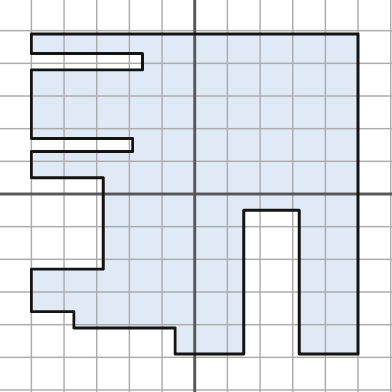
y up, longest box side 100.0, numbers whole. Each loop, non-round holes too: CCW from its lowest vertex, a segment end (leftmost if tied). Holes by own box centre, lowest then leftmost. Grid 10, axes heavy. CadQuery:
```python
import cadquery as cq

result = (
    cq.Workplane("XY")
    .moveTo(-6.0, -49.0)
    .lineTo(15.0, -49.0)
    .lineTo(15.0, -5.0)
    .lineTo(32.0, -5.0)
    .lineTo(32.0, -49.0)
    .lineTo(50.0, -49.0)
    .lineTo(50.0, 49.0)
    .lineTo(-50.0, 49.0)
    .lineTo(-50.0, 43.0)
    .lineTo(-16.0, 43.0)
    .lineTo(-16.0, 38.0)
    .lineTo(-50.0, 38.0)
    .lineTo(-50.0, 17.0)
    .lineTo(-19.0, 17.0)
    .lineTo(-19.0, 13.0)
    .lineTo(-50.0, 13.0)
    .lineTo(-50.0, 5.0)
    .lineTo(-28.0, 5.0)
    .lineTo(-28.0, -23.0)
    .lineTo(-50.0, -23.0)
    .lineTo(-50.0, -36.0)
    .lineTo(-37.0, -36.0)
    .lineTo(-37.0, -41.0)
    .lineTo(-6.0, -41.0)
    .close()
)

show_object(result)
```